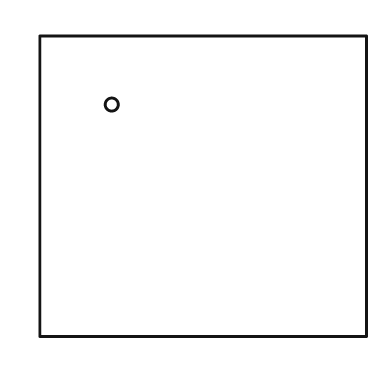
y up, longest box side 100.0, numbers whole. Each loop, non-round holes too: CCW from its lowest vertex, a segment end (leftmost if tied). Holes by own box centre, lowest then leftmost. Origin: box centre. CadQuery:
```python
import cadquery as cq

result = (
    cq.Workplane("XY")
    .moveTo(-50.0, -46.0)
    .lineTo(50.0, -46.0)
    .lineTo(50.0, 46.0)
    .lineTo(-50.0, 46.0)
    .close()
    .moveTo(-28.0, 25.0)
    .circle(2.0)
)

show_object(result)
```